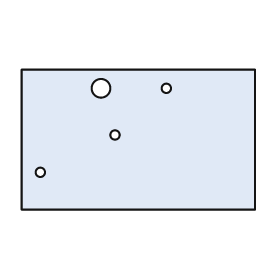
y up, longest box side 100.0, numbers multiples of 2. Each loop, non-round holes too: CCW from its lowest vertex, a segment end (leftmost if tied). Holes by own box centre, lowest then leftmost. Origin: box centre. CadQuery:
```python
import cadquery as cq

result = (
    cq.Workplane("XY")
    .moveTo(-50.0, -30.0)
    .lineTo(50.0, -30.0)
    .lineTo(50.0, 30.0)
    .lineTo(-50.0, 30.0)
    .close()
    .moveTo(-42.0, -14.0)
    .circle(2.0)
    .moveTo(-10.0, 2.0)
    .circle(2.0)
    .moveTo(-16.0, 22.0)
    .circle(4.0)
    .moveTo(12.0, 22.0)
    .circle(2.0)
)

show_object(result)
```